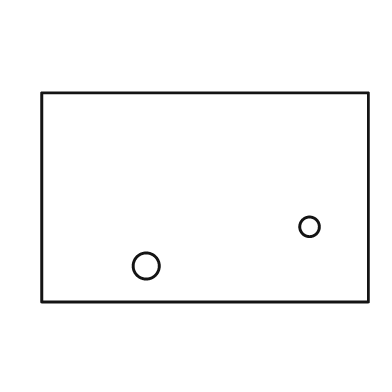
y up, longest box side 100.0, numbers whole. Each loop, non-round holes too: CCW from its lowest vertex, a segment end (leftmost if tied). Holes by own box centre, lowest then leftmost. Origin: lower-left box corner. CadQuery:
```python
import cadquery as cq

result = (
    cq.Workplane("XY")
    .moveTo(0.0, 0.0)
    .lineTo(100.0, 0.0)
    .lineTo(100.0, 64.0)
    .lineTo(0.0, 64.0)
    .close()
    .moveTo(32.0, 11.0)
    .circle(4.0)
    .moveTo(82.0, 23.0)
    .circle(3.0)
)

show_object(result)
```